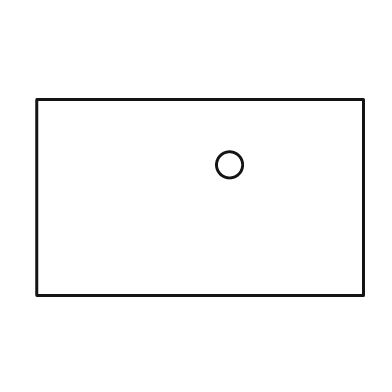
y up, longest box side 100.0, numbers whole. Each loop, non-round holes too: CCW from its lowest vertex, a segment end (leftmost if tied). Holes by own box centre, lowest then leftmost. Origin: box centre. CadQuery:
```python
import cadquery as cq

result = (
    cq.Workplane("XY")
    .moveTo(-50.0, -30.0)
    .lineTo(50.0, -30.0)
    .lineTo(50.0, 30.0)
    .lineTo(-50.0, 30.0)
    .close()
    .moveTo(9.0, 10.0)
    .circle(4.0)
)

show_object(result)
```